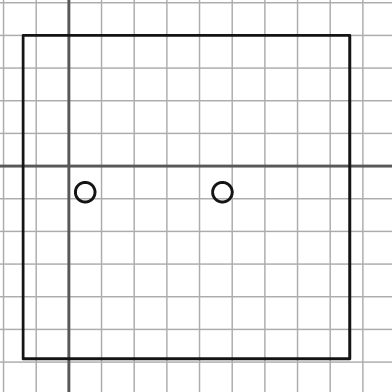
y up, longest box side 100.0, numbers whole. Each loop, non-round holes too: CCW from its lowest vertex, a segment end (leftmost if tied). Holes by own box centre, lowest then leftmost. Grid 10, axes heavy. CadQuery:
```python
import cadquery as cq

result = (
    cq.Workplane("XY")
    .moveTo(-14.0, -59.0)
    .lineTo(86.0, -59.0)
    .lineTo(86.0, 40.0)
    .lineTo(-14.0, 40.0)
    .close()
    .moveTo(5.0, -8.0)
    .circle(3.0)
    .moveTo(47.0, -8.0)
    .circle(3.0)
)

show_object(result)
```